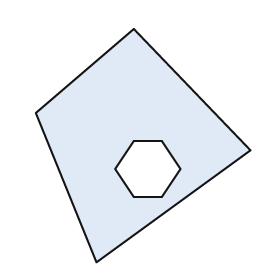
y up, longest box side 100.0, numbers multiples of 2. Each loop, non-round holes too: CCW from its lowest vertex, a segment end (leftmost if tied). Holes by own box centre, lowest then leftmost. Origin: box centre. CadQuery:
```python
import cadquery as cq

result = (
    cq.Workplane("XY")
    .moveTo(-20.0, -50.0)
    .lineTo(46.0, -2.0)
    .lineTo(-4.0, 50.0)
    .lineTo(-46.0, 14.0)
    .close()
    .moveTo(-4.0, -22.0)
    .lineTo(8.0, -22.0)
    .lineTo(16.0, -10.0)
    .lineTo(8.0, 2.0)
    .lineTo(-4.0, 2.0)
    .lineTo(-12.0, -10.0)
    .close()
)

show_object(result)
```